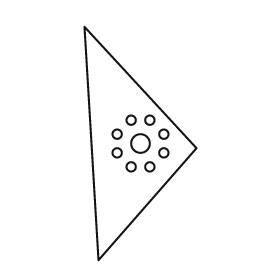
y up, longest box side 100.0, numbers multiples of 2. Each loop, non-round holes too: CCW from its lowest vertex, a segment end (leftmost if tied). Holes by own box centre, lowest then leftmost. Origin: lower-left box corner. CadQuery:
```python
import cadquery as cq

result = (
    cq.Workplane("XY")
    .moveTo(6.0, 0.0)
    .lineTo(48.0, 48.0)
    .lineTo(0.0, 100.0)
    .close()
    .moveTo(20.0, 40.0)
    .circle(2.0)
    .moveTo(28.0, 40.0)
    .circle(2.0)
    .moveTo(14.0, 46.0)
    .circle(2.0)
    .moveTo(34.0, 46.0)
    .circle(2.0)
    .moveTo(24.0, 50.0)
    .circle(4.0)
    .moveTo(14.0, 54.0)
    .circle(2.0)
    .moveTo(34.0, 54.0)
    .circle(2.0)
    .moveTo(20.0, 60.0)
    .circle(2.0)
    .moveTo(28.0, 60.0)
    .circle(2.0)
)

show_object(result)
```